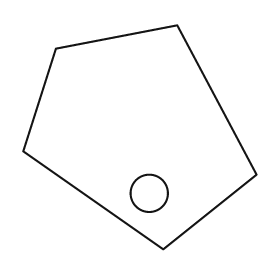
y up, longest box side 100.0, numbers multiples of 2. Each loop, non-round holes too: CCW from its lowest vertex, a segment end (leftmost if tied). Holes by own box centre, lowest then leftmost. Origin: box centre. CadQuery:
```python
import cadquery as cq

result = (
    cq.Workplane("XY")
    .moveTo(10.0, -48.0)
    .lineTo(50.0, -16.0)
    .lineTo(16.0, 48.0)
    .lineTo(-36.0, 38.0)
    .lineTo(-50.0, -6.0)
    .close()
    .moveTo(4.0, -24.0)
    .circle(8.0)
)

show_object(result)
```